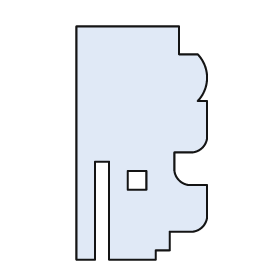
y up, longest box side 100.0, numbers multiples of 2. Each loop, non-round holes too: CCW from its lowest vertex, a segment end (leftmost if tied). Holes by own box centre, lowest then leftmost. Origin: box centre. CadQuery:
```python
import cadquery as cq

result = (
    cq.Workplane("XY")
    .moveTo(-28.0, -50.0)
    .lineTo(-20.0, -50.0)
    .lineTo(-20.0, -8.0)
    .lineTo(-14.0, -8.0)
    .lineTo(-14.0, -50.0)
    .lineTo(6.0, -50.0)
    .lineTo(6.0, -46.0)
    .lineTo(12.0, -46.0)
    .lineTo(12.0, -38.0)
    .lineTo(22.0, -38.0)
    .threePointArc((26.0, -36.0), (28.0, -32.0))
    .lineTo(28.0, -18.0)
    .lineTo(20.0, -18.0)
    .threePointArc((16.0, -16.0), (14.0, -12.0))
    .lineTo(14.0, -4.0)
    .lineTo(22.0, -4.0)
    .threePointArc((26.0, -2.0), (28.0, 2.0))
    .lineTo(28.0, 18.0)
    .lineTo(24.0, 18.0)
    .threePointArc((28.0, 28.0), (24.0, 38.0))
    .lineTo(16.0, 38.0)
    .lineTo(16.0, 50.0)
    .lineTo(-28.0, 50.0)
    .close()
    .moveTo(-6.0, -20.0)
    .lineTo(2.0, -20.0)
    .lineTo(2.0, -12.0)
    .lineTo(-6.0, -12.0)
    .close()
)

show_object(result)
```